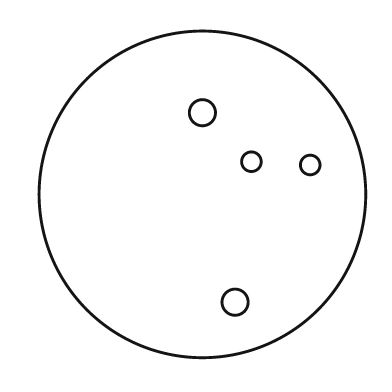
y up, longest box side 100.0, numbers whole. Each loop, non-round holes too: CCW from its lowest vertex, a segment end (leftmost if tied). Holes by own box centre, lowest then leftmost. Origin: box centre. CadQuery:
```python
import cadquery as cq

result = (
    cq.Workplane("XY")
    .moveTo(0.0, 0.0)
    .circle(50.0)
    .moveTo(10.0, -33.0)
    .circle(4.0)
    .moveTo(33.0, 9.0)
    .circle(3.0)
    .moveTo(15.0, 10.0)
    .circle(3.0)
    .moveTo(0.0, 25.0)
    .circle(4.0)
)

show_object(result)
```